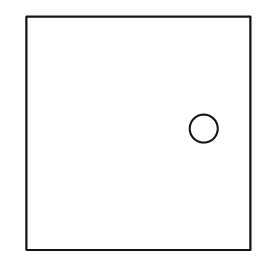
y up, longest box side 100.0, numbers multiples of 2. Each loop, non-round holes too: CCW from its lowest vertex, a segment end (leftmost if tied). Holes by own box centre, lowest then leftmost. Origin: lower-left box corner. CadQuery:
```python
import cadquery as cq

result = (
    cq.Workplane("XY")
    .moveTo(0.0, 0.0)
    .lineTo(96.0, 0.0)
    .lineTo(96.0, 100.0)
    .lineTo(0.0, 100.0)
    .close()
    .moveTo(76.0, 52.0)
    .circle(6.0)
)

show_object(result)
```